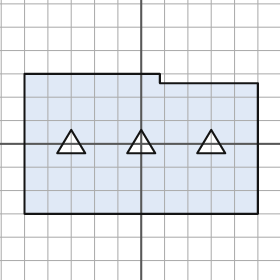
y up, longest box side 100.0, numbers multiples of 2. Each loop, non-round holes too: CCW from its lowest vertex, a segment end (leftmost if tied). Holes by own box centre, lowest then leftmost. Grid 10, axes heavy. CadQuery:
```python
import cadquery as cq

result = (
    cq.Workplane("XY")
    .moveTo(-50.0, -30.0)
    .lineTo(50.0, -30.0)
    .lineTo(50.0, 26.0)
    .lineTo(8.0, 26.0)
    .lineTo(8.0, 30.0)
    .lineTo(-50.0, 30.0)
    .close()
    .moveTo(-36.0, -4.0)
    .lineTo(-24.0, -4.0)
    .lineTo(-30.0, 6.0)
    .close()
    .moveTo(-6.0, -4.0)
    .lineTo(6.0, -4.0)
    .lineTo(0.0, 6.0)
    .close()
    .moveTo(24.0, -4.0)
    .lineTo(36.0, -4.0)
    .lineTo(30.0, 6.0)
    .close()
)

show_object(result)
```